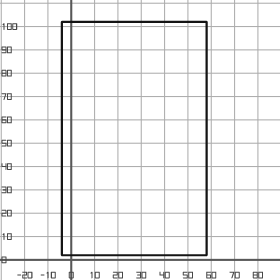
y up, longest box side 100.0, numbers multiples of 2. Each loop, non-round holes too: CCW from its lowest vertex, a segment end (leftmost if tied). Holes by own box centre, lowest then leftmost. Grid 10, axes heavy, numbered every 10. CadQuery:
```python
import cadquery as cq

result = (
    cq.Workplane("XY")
    .moveTo(-4.0, 2.0)
    .lineTo(58.0, 2.0)
    .lineTo(58.0, 102.0)
    .lineTo(-4.0, 102.0)
    .close()
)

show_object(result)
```